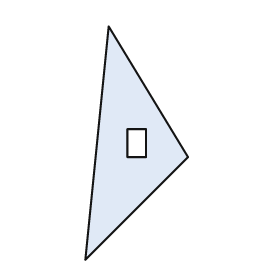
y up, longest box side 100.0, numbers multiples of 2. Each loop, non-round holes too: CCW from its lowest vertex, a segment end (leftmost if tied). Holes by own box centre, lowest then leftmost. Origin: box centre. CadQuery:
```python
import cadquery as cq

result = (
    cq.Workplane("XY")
    .moveTo(-22.0, -50.0)
    .lineTo(22.0, -6.0)
    .lineTo(-12.0, 50.0)
    .close()
    .moveTo(-4.0, -6.0)
    .lineTo(4.0, -6.0)
    .lineTo(4.0, 6.0)
    .lineTo(-4.0, 6.0)
    .close()
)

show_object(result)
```